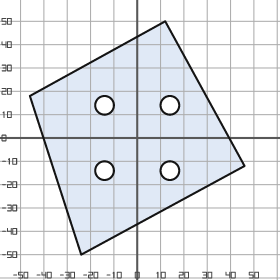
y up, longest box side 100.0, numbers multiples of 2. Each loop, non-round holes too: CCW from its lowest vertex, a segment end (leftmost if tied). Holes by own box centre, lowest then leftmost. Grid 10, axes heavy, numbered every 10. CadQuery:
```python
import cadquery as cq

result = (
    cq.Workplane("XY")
    .moveTo(-24.0, -50.0)
    .lineTo(46.0, -12.0)
    .lineTo(12.0, 50.0)
    .lineTo(-46.0, 18.0)
    .close()
    .moveTo(-14.0, -14.0)
    .circle(4.0)
    .moveTo(14.0, -14.0)
    .circle(4.0)
    .moveTo(-14.0, 14.0)
    .circle(4.0)
    .moveTo(14.0, 14.0)
    .circle(4.0)
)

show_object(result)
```